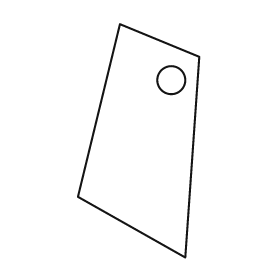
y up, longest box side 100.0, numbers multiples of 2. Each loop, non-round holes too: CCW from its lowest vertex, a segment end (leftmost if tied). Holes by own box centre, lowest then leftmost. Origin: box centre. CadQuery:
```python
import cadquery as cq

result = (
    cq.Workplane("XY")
    .moveTo(20.0, -50.0)
    .lineTo(26.0, 36.0)
    .lineTo(-8.0, 50.0)
    .lineTo(-26.0, -24.0)
    .close()
    .moveTo(14.0, 26.0)
    .circle(6.0)
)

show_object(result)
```